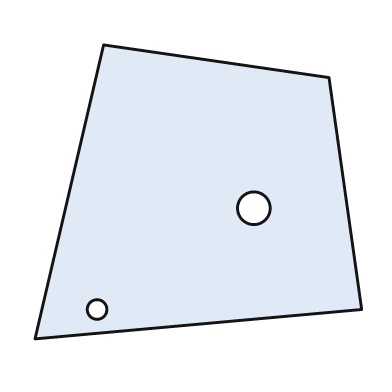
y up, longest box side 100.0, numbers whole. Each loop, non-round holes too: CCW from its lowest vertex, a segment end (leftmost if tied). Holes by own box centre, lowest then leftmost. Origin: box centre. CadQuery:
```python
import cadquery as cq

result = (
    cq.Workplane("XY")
    .moveTo(-50.0, -45.0)
    .lineTo(50.0, -36.0)
    .lineTo(40.0, 35.0)
    .lineTo(-29.0, 45.0)
    .close()
    .moveTo(-31.0, -36.0)
    .circle(3.0)
    .moveTo(17.0, -5.0)
    .circle(5.0)
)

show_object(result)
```